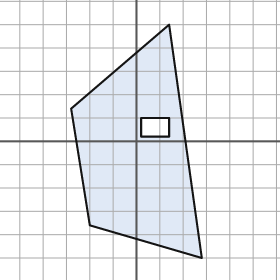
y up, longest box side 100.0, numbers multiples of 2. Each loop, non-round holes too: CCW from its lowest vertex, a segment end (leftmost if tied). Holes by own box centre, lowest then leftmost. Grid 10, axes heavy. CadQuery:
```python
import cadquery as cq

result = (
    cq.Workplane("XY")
    .moveTo(28.0, -50.0)
    .lineTo(14.0, 50.0)
    .lineTo(-28.0, 14.0)
    .lineTo(-20.0, -36.0)
    .close()
    .moveTo(2.0, 2.0)
    .lineTo(14.0, 2.0)
    .lineTo(14.0, 10.0)
    .lineTo(2.0, 10.0)
    .close()
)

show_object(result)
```